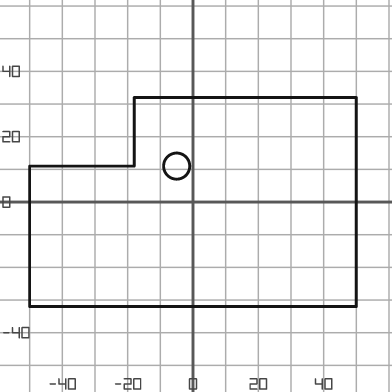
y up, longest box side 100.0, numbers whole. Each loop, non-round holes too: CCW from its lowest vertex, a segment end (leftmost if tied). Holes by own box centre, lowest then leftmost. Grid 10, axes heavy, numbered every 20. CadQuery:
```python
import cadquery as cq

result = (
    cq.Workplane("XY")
    .moveTo(-50.0, -32.0)
    .lineTo(50.0, -32.0)
    .lineTo(50.0, 32.0)
    .lineTo(-18.0, 32.0)
    .lineTo(-18.0, 11.0)
    .lineTo(-50.0, 11.0)
    .close()
    .moveTo(-5.0, 11.0)
    .circle(4.0)
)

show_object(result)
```